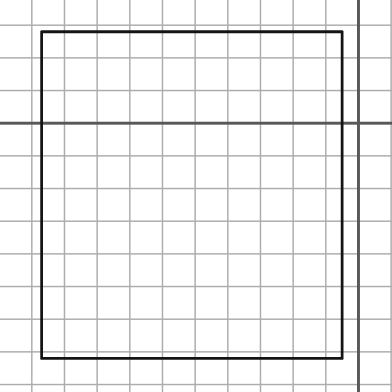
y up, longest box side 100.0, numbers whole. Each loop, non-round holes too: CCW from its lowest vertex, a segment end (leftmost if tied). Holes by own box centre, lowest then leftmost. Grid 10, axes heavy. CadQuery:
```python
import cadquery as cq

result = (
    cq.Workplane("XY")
    .moveTo(-97.0, -72.0)
    .lineTo(-5.0, -72.0)
    .lineTo(-5.0, 28.0)
    .lineTo(-97.0, 28.0)
    .close()
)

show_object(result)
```